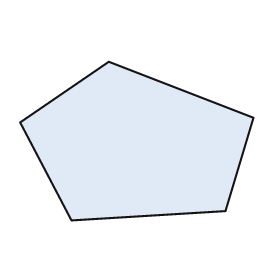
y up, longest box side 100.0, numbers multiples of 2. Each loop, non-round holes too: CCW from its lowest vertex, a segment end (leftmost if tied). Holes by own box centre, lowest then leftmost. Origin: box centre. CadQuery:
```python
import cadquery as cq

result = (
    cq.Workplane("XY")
    .moveTo(-28.0, -34.0)
    .lineTo(38.0, -30.0)
    .lineTo(50.0, 10.0)
    .lineTo(-12.0, 34.0)
    .lineTo(-50.0, 8.0)
    .close()
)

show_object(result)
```